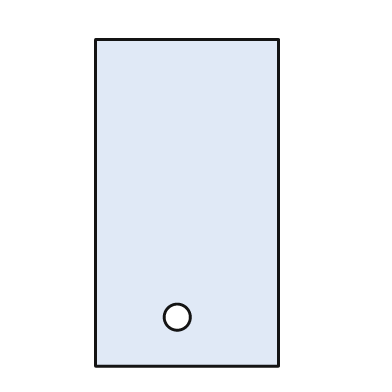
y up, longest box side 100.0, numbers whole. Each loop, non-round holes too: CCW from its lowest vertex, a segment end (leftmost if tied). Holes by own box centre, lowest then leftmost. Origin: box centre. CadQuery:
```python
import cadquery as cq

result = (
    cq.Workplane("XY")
    .moveTo(-28.0, -50.0)
    .lineTo(28.0, -50.0)
    .lineTo(28.0, 50.0)
    .lineTo(-28.0, 50.0)
    .close()
    .moveTo(-3.0, -35.0)
    .circle(4.0)
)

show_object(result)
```